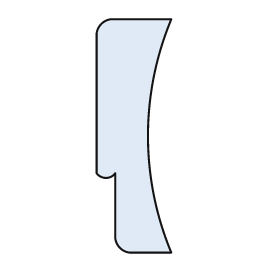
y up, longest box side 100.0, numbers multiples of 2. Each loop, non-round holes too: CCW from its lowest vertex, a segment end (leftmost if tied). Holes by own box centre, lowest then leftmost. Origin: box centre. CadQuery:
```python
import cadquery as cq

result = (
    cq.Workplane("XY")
    .moveTo(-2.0, -50.0)
    .lineTo(16.0, -50.0)
    .threePointArc((6.0, 0.0), (16.0, 50.0))
    .lineTo(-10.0, 50.0)
    .threePointArc((-14.0, 48.0), (-16.0, 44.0))
    .lineTo(-16.0, -16.0)
    .threePointArc((-12.0, -18.0), (-8.0, -16.0))
    .lineTo(-8.0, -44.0)
    .threePointArc((-6.0, -48.0), (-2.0, -50.0))
    .close()
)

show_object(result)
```